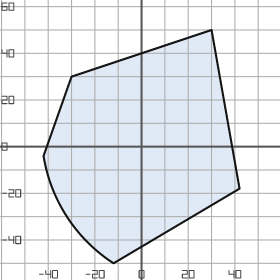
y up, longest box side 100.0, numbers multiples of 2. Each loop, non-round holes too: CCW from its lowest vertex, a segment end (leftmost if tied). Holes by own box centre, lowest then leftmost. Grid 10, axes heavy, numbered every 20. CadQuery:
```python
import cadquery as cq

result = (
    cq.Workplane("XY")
    .moveTo(-12.0, -50.0)
    .lineTo(42.0, -18.0)
    .lineTo(30.0, 50.0)
    .lineTo(-30.0, 30.0)
    .lineTo(-42.0, -4.0)
    .threePointArc((-32.0, -30.0), (-12.0, -50.0))
    .close()
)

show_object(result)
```